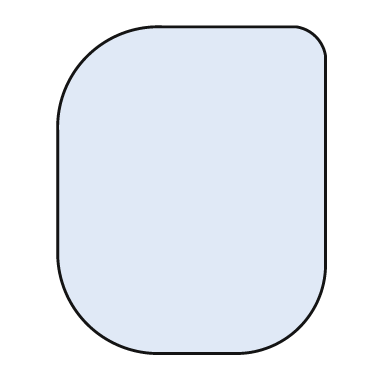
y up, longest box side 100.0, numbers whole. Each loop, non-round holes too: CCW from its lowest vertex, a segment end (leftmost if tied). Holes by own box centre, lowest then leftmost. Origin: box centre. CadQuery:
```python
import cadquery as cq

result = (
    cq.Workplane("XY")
    .moveTo(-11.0, -50.0)
    .lineTo(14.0, -50.0)
    .threePointArc((33.0, -42.0), (41.0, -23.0))
    .lineTo(41.0, 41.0)
    .threePointArc((38.0, 47.0), (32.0, 50.0))
    .lineTo(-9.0, 50.0)
    .threePointArc((-32.0, 41.0), (-41.0, 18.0))
    .lineTo(-41.0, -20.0)
    .threePointArc((-32.0, -41.0), (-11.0, -50.0))
    .close()
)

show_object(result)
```